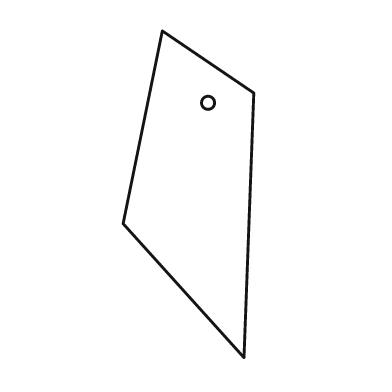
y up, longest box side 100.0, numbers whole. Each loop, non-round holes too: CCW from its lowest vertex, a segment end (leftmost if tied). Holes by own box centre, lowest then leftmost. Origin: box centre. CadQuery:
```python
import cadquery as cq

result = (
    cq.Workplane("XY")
    .moveTo(17.0, -50.0)
    .lineTo(20.0, 31.0)
    .lineTo(-8.0, 50.0)
    .lineTo(-20.0, -9.0)
    .close()
    .moveTo(6.0, 28.0)
    .circle(2.0)
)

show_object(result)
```